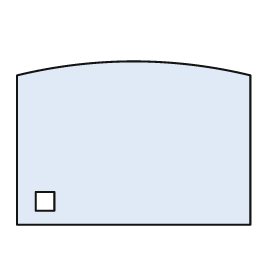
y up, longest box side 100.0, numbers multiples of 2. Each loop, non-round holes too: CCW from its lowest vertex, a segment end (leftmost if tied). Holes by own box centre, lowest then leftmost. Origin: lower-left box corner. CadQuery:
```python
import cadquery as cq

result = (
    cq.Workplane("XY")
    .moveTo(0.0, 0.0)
    .lineTo(100.0, 0.0)
    .lineTo(100.0, 64.0)
    .threePointArc((50.0, 70.0), (0.0, 64.0))
    .close()
    .moveTo(8.0, 6.0)
    .lineTo(16.0, 6.0)
    .lineTo(16.0, 14.0)
    .lineTo(8.0, 14.0)
    .close()
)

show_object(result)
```